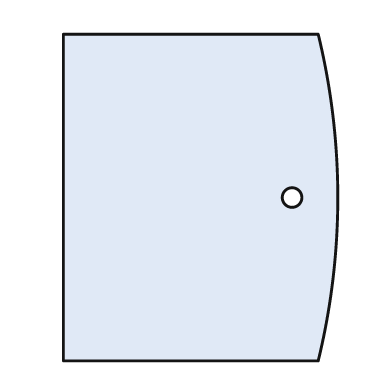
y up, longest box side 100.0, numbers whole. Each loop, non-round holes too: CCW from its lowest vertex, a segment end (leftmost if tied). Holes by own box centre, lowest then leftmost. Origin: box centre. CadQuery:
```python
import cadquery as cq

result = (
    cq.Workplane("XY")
    .moveTo(-42.0, -50.0)
    .lineTo(36.0, -50.0)
    .threePointArc((42.0, 0.0), (36.0, 50.0))
    .lineTo(-42.0, 50.0)
    .close()
    .moveTo(28.0, 0.0)
    .circle(3.0)
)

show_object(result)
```